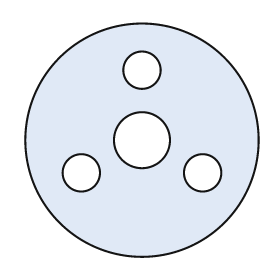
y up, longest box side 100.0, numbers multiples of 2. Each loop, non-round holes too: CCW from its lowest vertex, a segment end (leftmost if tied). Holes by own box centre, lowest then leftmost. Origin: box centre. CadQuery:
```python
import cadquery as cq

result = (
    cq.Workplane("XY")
    .moveTo(0.0, 0.0)
    .circle(50.0)
    .moveTo(-26.0, -14.0)
    .circle(8.0)
    .moveTo(26.0, -14.0)
    .circle(8.0)
    .moveTo(0.0, 0.0)
    .circle(12.0)
    .moveTo(0.0, 30.0)
    .circle(8.0)
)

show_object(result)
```